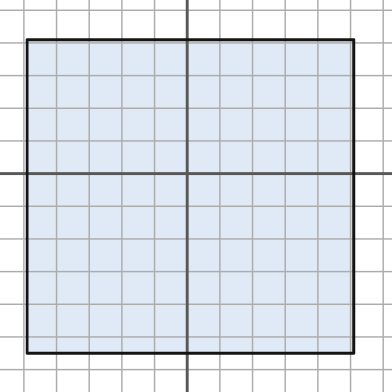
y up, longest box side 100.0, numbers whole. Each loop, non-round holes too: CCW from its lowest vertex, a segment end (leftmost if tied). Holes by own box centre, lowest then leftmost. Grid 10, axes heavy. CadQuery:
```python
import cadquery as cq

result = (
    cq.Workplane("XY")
    .moveTo(-49.0, -55.0)
    .lineTo(51.0, -55.0)
    .lineTo(51.0, 41.0)
    .lineTo(-49.0, 41.0)
    .close()
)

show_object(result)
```